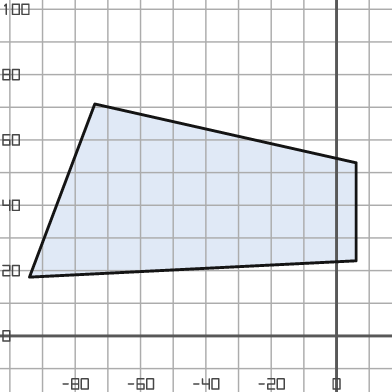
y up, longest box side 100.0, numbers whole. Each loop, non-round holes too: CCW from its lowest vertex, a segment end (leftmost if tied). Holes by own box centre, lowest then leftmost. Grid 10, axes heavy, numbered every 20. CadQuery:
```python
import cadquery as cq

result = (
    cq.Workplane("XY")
    .moveTo(-94.0, 18.0)
    .lineTo(6.0, 23.0)
    .lineTo(6.0, 53.0)
    .lineTo(-74.0, 71.0)
    .close()
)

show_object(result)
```